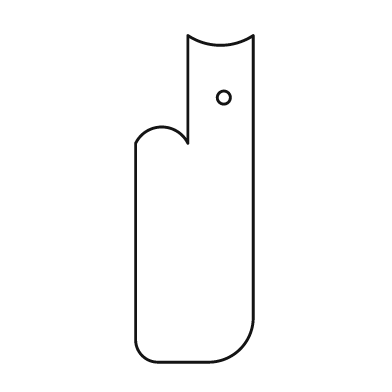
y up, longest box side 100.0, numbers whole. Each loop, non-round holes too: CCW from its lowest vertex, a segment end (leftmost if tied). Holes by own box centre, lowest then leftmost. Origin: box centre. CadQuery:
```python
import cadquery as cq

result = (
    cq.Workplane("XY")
    .moveTo(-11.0, -50.0)
    .lineTo(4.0, -50.0)
    .threePointArc((14.0, -46.0), (18.0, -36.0))
    .lineTo(18.0, 50.0)
    .threePointArc((8.0, 47.0), (-2.0, 50.0))
    .lineTo(-2.0, 17.0)
    .threePointArc((-10.0, 22.0), (-18.0, 17.0))
    .lineTo(-18.0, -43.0)
    .threePointArc((-16.0, -48.0), (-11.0, -50.0))
    .close()
    .moveTo(9.0, 31.0)
    .circle(2.0)
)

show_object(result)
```